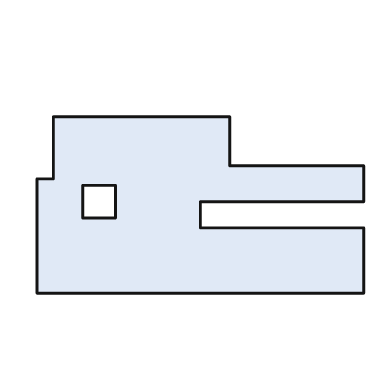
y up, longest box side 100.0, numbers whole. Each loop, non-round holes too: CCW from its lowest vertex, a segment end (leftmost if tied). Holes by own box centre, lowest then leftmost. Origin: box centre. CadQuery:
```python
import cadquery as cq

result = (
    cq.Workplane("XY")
    .moveTo(-50.0, -27.0)
    .lineTo(50.0, -27.0)
    .lineTo(50.0, -7.0)
    .lineTo(0.0, -7.0)
    .lineTo(0.0, 1.0)
    .lineTo(50.0, 1.0)
    .lineTo(50.0, 12.0)
    .lineTo(9.0, 12.0)
    .lineTo(9.0, 27.0)
    .lineTo(-45.0, 27.0)
    .lineTo(-45.0, 8.0)
    .lineTo(-50.0, 8.0)
    .close()
    .moveTo(-36.0, -4.0)
    .lineTo(-26.0, -4.0)
    .lineTo(-26.0, 6.0)
    .lineTo(-36.0, 6.0)
    .close()
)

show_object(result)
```